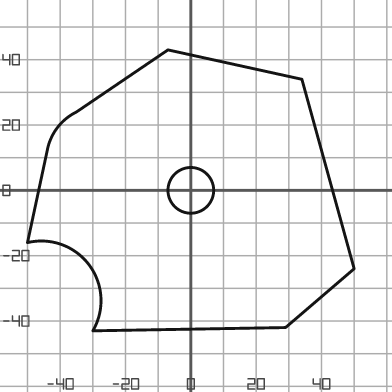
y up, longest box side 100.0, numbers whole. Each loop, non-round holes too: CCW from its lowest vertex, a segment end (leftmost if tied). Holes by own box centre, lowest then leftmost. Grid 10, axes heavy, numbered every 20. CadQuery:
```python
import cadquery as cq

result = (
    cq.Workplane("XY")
    .moveTo(-30.0, -43.0)
    .lineTo(29.0, -42.0)
    .lineTo(50.0, -24.0)
    .lineTo(34.0, 34.0)
    .lineTo(-7.0, 43.0)
    .lineTo(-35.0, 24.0)
    .threePointArc((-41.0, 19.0), (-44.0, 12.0))
    .lineTo(-50.0, -16.0)
    .threePointArc((-31.0, -23.0), (-30.0, -43.0))
    .close()
    .moveTo(0.0, 0.0)
    .circle(7.0)
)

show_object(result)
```